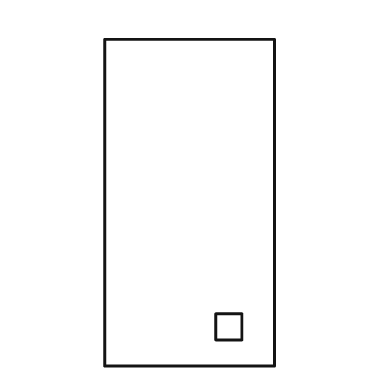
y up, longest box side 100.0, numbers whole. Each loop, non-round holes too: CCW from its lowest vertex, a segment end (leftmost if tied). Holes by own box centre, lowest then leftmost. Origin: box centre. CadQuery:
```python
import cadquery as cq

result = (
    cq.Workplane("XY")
    .moveTo(-26.0, -50.0)
    .lineTo(26.0, -50.0)
    .lineTo(26.0, 50.0)
    .lineTo(-26.0, 50.0)
    .close()
    .moveTo(8.0, -42.0)
    .lineTo(16.0, -42.0)
    .lineTo(16.0, -34.0)
    .lineTo(8.0, -34.0)
    .close()
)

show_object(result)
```